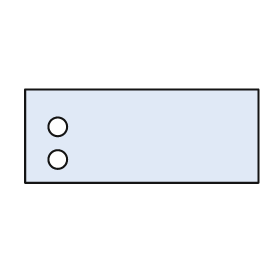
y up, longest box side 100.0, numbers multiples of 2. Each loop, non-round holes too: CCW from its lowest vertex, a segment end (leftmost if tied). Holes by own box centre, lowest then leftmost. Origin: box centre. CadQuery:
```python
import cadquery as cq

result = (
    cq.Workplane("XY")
    .moveTo(-50.0, -20.0)
    .lineTo(50.0, -20.0)
    .lineTo(50.0, 20.0)
    .lineTo(-50.0, 20.0)
    .close()
    .moveTo(-36.0, -10.0)
    .circle(4.0)
    .moveTo(-36.0, 4.0)
    .circle(4.0)
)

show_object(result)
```